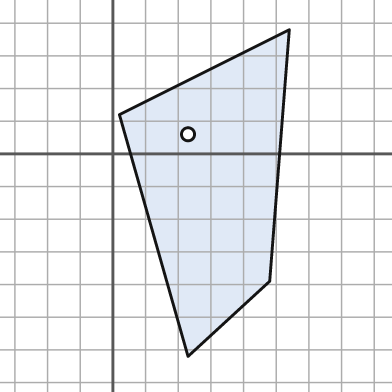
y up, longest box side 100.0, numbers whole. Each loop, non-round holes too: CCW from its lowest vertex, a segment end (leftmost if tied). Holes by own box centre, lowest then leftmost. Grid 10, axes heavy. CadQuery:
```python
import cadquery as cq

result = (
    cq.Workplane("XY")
    .moveTo(23.0, -62.0)
    .lineTo(48.0, -39.0)
    .lineTo(54.0, 38.0)
    .lineTo(2.0, 12.0)
    .close()
    .moveTo(23.0, 6.0)
    .circle(2.0)
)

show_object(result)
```